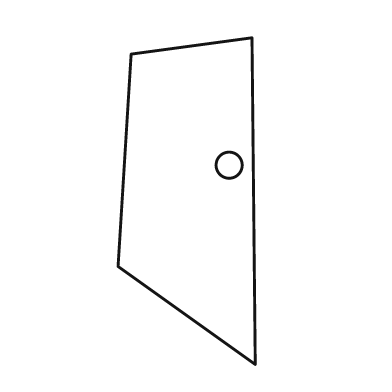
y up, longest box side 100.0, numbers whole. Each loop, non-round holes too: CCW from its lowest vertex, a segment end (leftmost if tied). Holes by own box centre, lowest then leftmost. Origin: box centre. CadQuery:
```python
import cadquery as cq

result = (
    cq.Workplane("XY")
    .moveTo(21.0, -50.0)
    .lineTo(20.0, 50.0)
    .lineTo(-17.0, 45.0)
    .lineTo(-21.0, -20.0)
    .close()
    .moveTo(13.0, 11.0)
    .circle(4.0)
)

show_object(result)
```